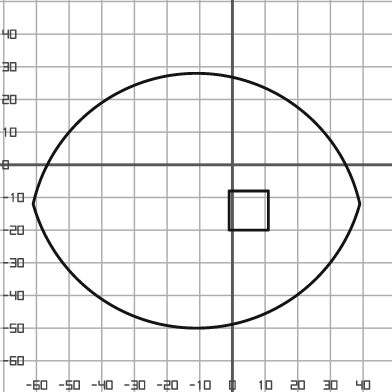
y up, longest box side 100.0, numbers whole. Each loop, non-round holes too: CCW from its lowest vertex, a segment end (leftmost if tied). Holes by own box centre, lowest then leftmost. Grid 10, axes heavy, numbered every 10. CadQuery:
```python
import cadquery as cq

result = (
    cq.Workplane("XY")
    .moveTo(-61.0, -12.0)
    .threePointArc((-11.0, -50.0), (39.0, -12.0))
    .threePointArc((-11.0, 28.0), (-61.0, -12.0))
    .close()
    .moveTo(-1.0, -20.0)
    .lineTo(11.0, -20.0)
    .lineTo(11.0, -8.0)
    .lineTo(-1.0, -8.0)
    .close()
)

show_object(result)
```